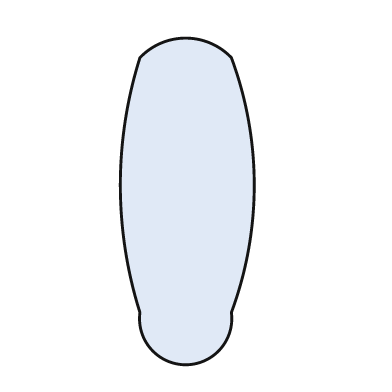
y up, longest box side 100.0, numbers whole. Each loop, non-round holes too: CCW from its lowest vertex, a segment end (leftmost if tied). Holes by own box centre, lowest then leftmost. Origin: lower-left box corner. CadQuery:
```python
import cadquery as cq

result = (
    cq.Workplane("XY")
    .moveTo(6.0, 16.0)
    .threePointArc((20.0, 0.0), (34.0, 16.0))
    .threePointArc((41.0, 55.0), (34.0, 94.0))
    .threePointArc((20.0, 100.0), (6.0, 94.0))
    .threePointArc((0.0, 55.0), (6.0, 16.0))
    .close()
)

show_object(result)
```